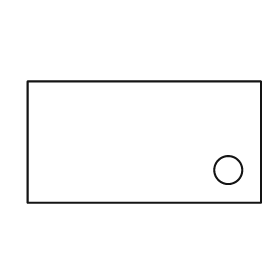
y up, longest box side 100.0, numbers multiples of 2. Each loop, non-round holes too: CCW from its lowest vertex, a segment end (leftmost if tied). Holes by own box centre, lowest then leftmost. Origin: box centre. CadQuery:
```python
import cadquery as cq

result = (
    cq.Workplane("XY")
    .moveTo(-50.0, -26.0)
    .lineTo(50.0, -26.0)
    .lineTo(50.0, 26.0)
    .lineTo(-50.0, 26.0)
    .close()
    .moveTo(36.0, -12.0)
    .circle(6.0)
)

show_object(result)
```